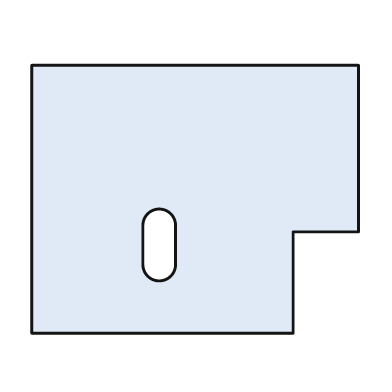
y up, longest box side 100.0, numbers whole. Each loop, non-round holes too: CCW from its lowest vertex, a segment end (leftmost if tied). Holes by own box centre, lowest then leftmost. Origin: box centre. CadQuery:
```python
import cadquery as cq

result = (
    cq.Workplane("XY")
    .moveTo(-50.0, -41.0)
    .lineTo(30.0, -41.0)
    .lineTo(30.0, -10.0)
    .lineTo(50.0, -10.0)
    .lineTo(50.0, 41.0)
    .lineTo(-50.0, 41.0)
    .close()
    .moveTo(-16.0, -20.0)
    .threePointArc((-11.0, -25.0), (-6.0, -20.0))
    .lineTo(-6.0, -8.0)
    .threePointArc((-11.0, -3.0), (-16.0, -8.0))
    .close()
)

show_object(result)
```